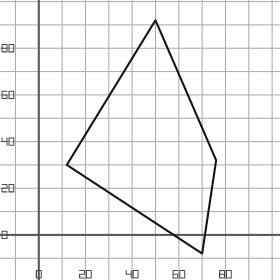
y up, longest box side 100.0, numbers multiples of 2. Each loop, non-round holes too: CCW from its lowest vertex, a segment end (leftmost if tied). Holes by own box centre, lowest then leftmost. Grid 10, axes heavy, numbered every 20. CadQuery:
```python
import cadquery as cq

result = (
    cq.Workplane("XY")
    .moveTo(70.0, -8.0)
    .lineTo(76.0, 32.0)
    .lineTo(50.0, 92.0)
    .lineTo(12.0, 30.0)
    .close()
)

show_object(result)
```